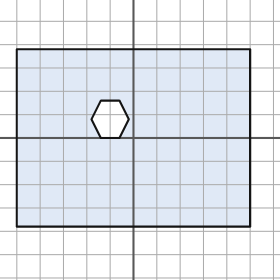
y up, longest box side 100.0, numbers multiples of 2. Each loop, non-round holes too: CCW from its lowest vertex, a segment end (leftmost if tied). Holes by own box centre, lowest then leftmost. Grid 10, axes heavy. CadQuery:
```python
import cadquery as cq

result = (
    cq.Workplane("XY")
    .moveTo(-50.0, -38.0)
    .lineTo(50.0, -38.0)
    .lineTo(50.0, 38.0)
    .lineTo(-50.0, 38.0)
    .close()
    .moveTo(-14.0, 0.0)
    .lineTo(-6.0, 0.0)
    .lineTo(-2.0, 8.0)
    .lineTo(-6.0, 16.0)
    .lineTo(-14.0, 16.0)
    .lineTo(-18.0, 8.0)
    .close()
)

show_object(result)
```